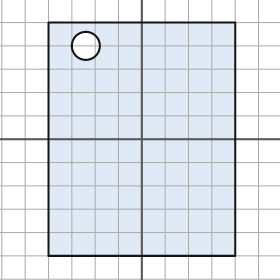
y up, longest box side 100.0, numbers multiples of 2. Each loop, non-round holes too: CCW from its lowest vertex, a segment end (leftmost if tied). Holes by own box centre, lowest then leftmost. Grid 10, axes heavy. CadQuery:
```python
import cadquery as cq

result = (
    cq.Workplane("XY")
    .moveTo(-40.0, -50.0)
    .lineTo(40.0, -50.0)
    .lineTo(40.0, 50.0)
    .lineTo(-40.0, 50.0)
    .close()
    .moveTo(-24.0, 40.0)
    .circle(6.0)
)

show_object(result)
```